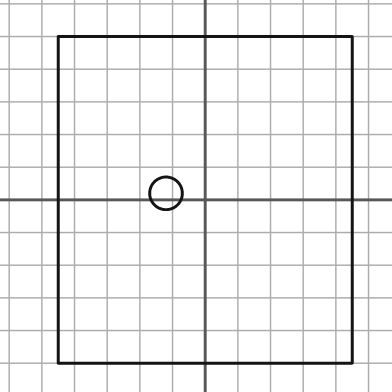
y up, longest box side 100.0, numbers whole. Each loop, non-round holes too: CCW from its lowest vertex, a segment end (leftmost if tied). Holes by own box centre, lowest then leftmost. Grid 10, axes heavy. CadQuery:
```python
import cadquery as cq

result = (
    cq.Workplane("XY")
    .moveTo(-45.0, -50.0)
    .lineTo(45.0, -50.0)
    .lineTo(45.0, 50.0)
    .lineTo(-45.0, 50.0)
    .close()
    .moveTo(-12.0, 2.0)
    .circle(5.0)
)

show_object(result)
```